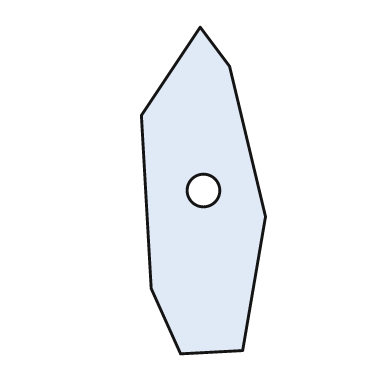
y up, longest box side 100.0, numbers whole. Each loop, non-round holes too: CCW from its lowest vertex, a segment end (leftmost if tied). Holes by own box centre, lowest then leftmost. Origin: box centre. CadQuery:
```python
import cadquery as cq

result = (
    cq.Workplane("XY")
    .moveTo(-7.0, -50.0)
    .lineTo(12.0, -49.0)
    .lineTo(19.0, -8.0)
    .lineTo(8.0, 38.0)
    .lineTo(-1.0, 50.0)
    .lineTo(-19.0, 23.0)
    .lineTo(-16.0, -30.0)
    .close()
    .moveTo(0.0, 0.0)
    .circle(5.0)
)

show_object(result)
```